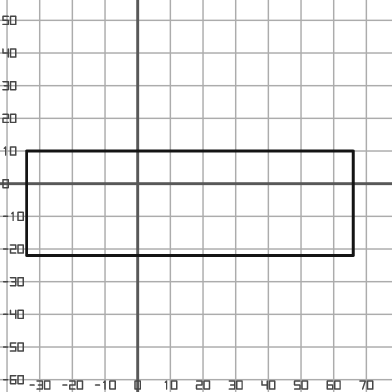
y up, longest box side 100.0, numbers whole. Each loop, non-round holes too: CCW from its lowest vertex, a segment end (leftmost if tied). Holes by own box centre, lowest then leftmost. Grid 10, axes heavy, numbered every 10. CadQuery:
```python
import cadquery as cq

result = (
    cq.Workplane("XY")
    .moveTo(-34.0, -22.0)
    .lineTo(66.0, -22.0)
    .lineTo(66.0, 10.0)
    .lineTo(-34.0, 10.0)
    .close()
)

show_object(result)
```